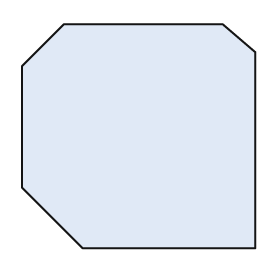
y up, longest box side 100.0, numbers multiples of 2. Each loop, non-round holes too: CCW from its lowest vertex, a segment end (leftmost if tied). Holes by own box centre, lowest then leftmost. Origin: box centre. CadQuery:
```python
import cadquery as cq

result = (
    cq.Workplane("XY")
    .moveTo(-24.0, -48.0)
    .lineTo(50.0, -48.0)
    .lineTo(50.0, 36.0)
    .lineTo(36.0, 48.0)
    .lineTo(-32.0, 48.0)
    .lineTo(-50.0, 30.0)
    .lineTo(-50.0, -22.0)
    .close()
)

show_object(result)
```